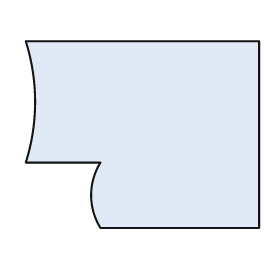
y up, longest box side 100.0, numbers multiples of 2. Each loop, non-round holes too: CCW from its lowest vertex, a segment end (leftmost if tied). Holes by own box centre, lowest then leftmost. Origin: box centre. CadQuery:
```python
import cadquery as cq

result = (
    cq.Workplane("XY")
    .moveTo(-18.0, -40.0)
    .lineTo(50.0, -40.0)
    .lineTo(50.0, 40.0)
    .lineTo(-50.0, 40.0)
    .threePointArc((-46.0, 14.0), (-50.0, -12.0))
    .lineTo(-18.0, -12.0)
    .threePointArc((-22.0, -26.0), (-18.0, -40.0))
    .close()
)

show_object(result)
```